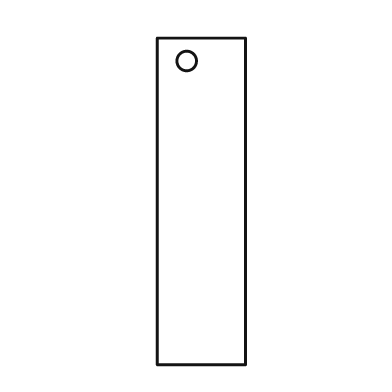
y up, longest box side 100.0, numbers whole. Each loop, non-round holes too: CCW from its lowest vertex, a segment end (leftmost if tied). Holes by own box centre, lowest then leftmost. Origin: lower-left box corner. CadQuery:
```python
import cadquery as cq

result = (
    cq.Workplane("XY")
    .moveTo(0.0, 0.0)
    .lineTo(27.0, 0.0)
    .lineTo(27.0, 100.0)
    .lineTo(0.0, 100.0)
    .close()
    .moveTo(9.0, 93.0)
    .circle(3.0)
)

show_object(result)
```